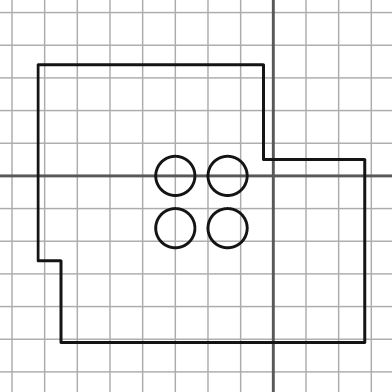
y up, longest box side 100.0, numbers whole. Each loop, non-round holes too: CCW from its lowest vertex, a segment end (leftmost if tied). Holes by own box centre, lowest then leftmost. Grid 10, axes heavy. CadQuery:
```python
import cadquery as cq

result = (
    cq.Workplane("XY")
    .moveTo(-65.0, -51.0)
    .lineTo(28.0, -51.0)
    .lineTo(28.0, 5.0)
    .lineTo(-3.0, 5.0)
    .lineTo(-3.0, 34.0)
    .lineTo(-72.0, 34.0)
    .lineTo(-72.0, -26.0)
    .lineTo(-65.0, -26.0)
    .close()
    .moveTo(-30.0, -16.0)
    .circle(6.0)
    .moveTo(-14.0, -16.0)
    .circle(6.0)
    .moveTo(-30.0, 0.0)
    .circle(6.0)
    .moveTo(-14.0, 0.0)
    .circle(6.0)
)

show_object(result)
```